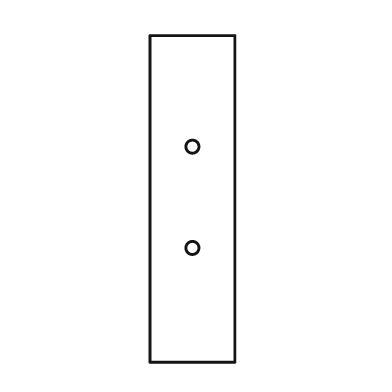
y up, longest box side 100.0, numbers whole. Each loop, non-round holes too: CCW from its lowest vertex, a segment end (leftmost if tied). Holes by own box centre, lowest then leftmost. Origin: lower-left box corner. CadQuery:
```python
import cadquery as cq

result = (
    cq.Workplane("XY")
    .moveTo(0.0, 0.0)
    .lineTo(26.0, 0.0)
    .lineTo(26.0, 100.0)
    .lineTo(0.0, 100.0)
    .close()
    .moveTo(13.0, 35.0)
    .circle(2.0)
    .moveTo(13.0, 66.0)
    .circle(2.0)
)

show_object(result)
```